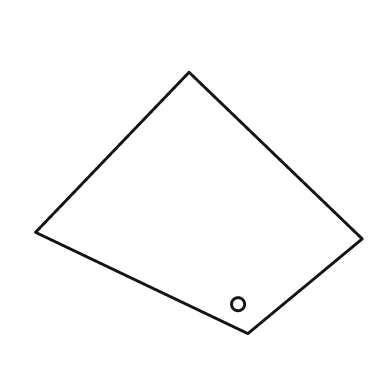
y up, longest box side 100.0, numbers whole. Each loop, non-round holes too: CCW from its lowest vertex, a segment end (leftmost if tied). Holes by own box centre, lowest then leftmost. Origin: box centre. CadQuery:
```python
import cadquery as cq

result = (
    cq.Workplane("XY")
    .moveTo(15.0, -40.0)
    .lineTo(50.0, -11.0)
    .lineTo(-3.0, 40.0)
    .lineTo(-50.0, -9.0)
    .close()
    .moveTo(12.0, -31.0)
    .circle(2.0)
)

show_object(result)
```